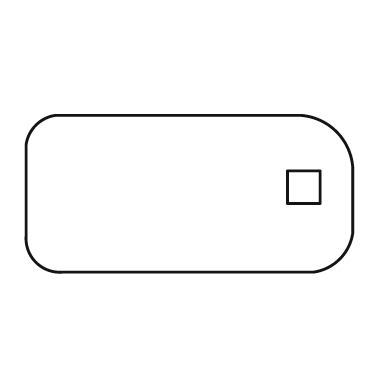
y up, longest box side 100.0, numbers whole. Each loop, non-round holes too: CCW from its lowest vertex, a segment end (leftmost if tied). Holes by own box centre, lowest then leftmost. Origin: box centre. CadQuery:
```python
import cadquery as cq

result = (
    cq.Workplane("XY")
    .moveTo(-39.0, -24.0)
    .lineTo(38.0, -24.0)
    .threePointArc((46.0, -20.0), (50.0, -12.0))
    .lineTo(50.0, 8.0)
    .threePointArc((45.0, 19.0), (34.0, 24.0))
    .lineTo(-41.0, 24.0)
    .threePointArc((-47.0, 21.0), (-50.0, 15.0))
    .lineTo(-50.0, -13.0)
    .threePointArc((-47.0, -21.0), (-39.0, -24.0))
    .close()
    .moveTo(30.0, -3.0)
    .lineTo(40.0, -3.0)
    .lineTo(40.0, 7.0)
    .lineTo(30.0, 7.0)
    .close()
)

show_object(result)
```